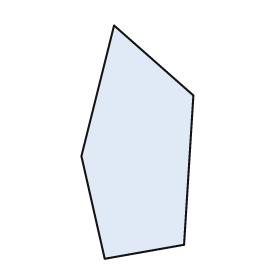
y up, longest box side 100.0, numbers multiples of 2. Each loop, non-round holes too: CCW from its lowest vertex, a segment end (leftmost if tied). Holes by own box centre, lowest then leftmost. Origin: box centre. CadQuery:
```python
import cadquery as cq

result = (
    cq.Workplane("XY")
    .moveTo(-14.0, -50.0)
    .lineTo(20.0, -44.0)
    .lineTo(24.0, 20.0)
    .lineTo(-10.0, 50.0)
    .lineTo(-24.0, -6.0)
    .close()
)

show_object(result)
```